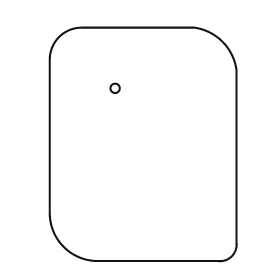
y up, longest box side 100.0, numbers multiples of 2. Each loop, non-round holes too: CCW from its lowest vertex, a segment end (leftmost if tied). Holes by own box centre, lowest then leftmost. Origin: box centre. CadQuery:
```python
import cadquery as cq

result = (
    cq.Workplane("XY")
    .moveTo(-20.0, -50.0)
    .lineTo(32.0, -50.0)
    .threePointArc((38.0, -48.0), (40.0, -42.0))
    .lineTo(40.0, 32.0)
    .threePointArc((34.0, 44.0), (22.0, 50.0))
    .lineTo(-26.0, 50.0)
    .threePointArc((-36.0, 46.0), (-40.0, 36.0))
    .lineTo(-40.0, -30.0)
    .threePointArc((-34.0, -44.0), (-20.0, -50.0))
    .close()
    .moveTo(-12.0, 24.0)
    .circle(2.0)
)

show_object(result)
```